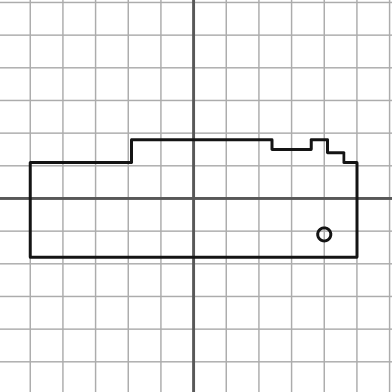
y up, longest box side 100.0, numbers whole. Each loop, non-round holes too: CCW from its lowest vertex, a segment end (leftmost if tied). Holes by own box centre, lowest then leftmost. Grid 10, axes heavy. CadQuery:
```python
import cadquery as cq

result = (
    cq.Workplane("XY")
    .moveTo(-50.0, -18.0)
    .lineTo(50.0, -18.0)
    .lineTo(50.0, 11.0)
    .lineTo(46.0, 11.0)
    .lineTo(46.0, 14.0)
    .lineTo(41.0, 14.0)
    .lineTo(41.0, 18.0)
    .lineTo(36.0, 18.0)
    .lineTo(36.0, 15.0)
    .lineTo(24.0, 15.0)
    .lineTo(24.0, 18.0)
    .lineTo(-19.0, 18.0)
    .lineTo(-19.0, 11.0)
    .lineTo(-50.0, 11.0)
    .close()
    .moveTo(40.0, -11.0)
    .circle(2.0)
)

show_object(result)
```